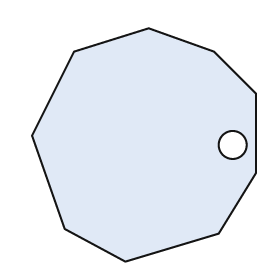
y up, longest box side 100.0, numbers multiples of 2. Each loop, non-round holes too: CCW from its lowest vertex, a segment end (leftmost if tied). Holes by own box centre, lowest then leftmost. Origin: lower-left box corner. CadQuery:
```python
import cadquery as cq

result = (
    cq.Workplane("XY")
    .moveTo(40.0, 0.0)
    .lineTo(80.0, 12.0)
    .lineTo(96.0, 38.0)
    .lineTo(96.0, 72.0)
    .lineTo(78.0, 90.0)
    .lineTo(50.0, 100.0)
    .lineTo(18.0, 90.0)
    .lineTo(0.0, 54.0)
    .lineTo(14.0, 14.0)
    .close()
    .moveTo(86.0, 50.0)
    .circle(6.0)
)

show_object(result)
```